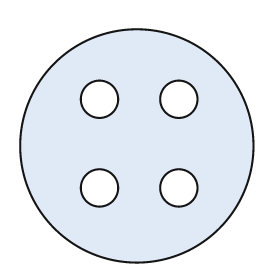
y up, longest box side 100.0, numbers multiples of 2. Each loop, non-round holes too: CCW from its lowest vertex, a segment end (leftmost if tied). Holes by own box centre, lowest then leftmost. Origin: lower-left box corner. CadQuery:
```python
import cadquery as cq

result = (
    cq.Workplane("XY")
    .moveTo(50.0, 50.0)
    .circle(50.0)
    .moveTo(34.0, 32.0)
    .circle(8.0)
    .moveTo(68.0, 32.0)
    .circle(8.0)
    .moveTo(34.0, 70.0)
    .circle(8.0)
    .moveTo(68.0, 70.0)
    .circle(8.0)
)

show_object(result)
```